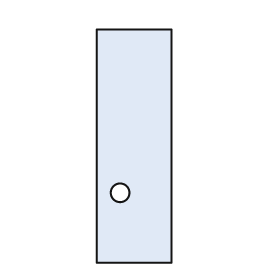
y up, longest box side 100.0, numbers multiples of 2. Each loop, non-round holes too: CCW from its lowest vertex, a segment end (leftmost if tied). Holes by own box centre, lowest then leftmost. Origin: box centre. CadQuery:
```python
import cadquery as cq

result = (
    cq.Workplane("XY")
    .moveTo(-16.0, -50.0)
    .lineTo(16.0, -50.0)
    .lineTo(16.0, 50.0)
    .lineTo(-16.0, 50.0)
    .close()
    .moveTo(-6.0, -20.0)
    .circle(4.0)
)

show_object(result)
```